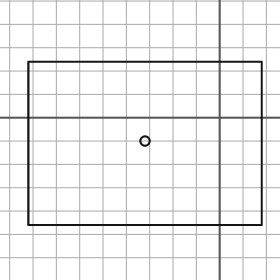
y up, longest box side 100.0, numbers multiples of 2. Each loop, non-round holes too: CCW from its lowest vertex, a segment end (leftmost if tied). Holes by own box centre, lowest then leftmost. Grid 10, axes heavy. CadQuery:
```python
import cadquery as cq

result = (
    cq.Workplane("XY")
    .moveTo(-82.0, -46.0)
    .lineTo(18.0, -46.0)
    .lineTo(18.0, 24.0)
    .lineTo(-82.0, 24.0)
    .close()
    .moveTo(-32.0, -10.0)
    .circle(2.0)
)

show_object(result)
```